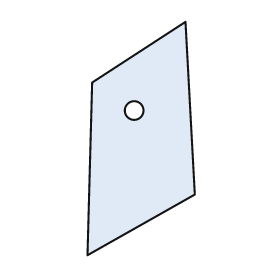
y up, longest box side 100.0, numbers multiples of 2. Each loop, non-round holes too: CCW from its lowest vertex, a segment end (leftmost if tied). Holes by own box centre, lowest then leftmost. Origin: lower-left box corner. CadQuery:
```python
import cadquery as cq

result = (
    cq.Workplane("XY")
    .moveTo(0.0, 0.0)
    .lineTo(46.0, 26.0)
    .lineTo(42.0, 100.0)
    .lineTo(2.0, 74.0)
    .close()
    .moveTo(20.0, 62.0)
    .circle(4.0)
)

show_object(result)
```